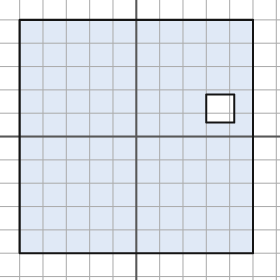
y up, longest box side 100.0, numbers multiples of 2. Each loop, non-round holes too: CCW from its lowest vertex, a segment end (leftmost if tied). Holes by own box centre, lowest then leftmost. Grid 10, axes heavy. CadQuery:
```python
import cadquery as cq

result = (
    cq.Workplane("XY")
    .moveTo(-50.0, -50.0)
    .lineTo(50.0, -50.0)
    .lineTo(50.0, 50.0)
    .lineTo(-50.0, 50.0)
    .close()
    .moveTo(30.0, 6.0)
    .lineTo(42.0, 6.0)
    .lineTo(42.0, 18.0)
    .lineTo(30.0, 18.0)
    .close()
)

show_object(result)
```